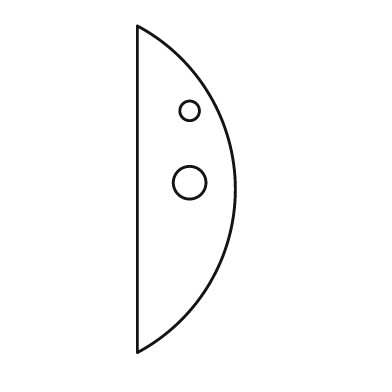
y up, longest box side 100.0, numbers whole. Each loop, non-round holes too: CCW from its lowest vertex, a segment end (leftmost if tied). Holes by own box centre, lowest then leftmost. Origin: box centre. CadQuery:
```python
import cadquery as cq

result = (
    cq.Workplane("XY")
    .moveTo(-15.0, -50.0)
    .threePointArc((15.0, 0.0), (-15.0, 50.0))
    .close()
    .moveTo(1.0, 2.0)
    .circle(5.0)
    .moveTo(1.0, 24.0)
    .circle(3.0)
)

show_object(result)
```